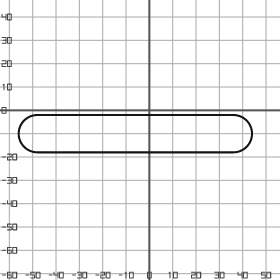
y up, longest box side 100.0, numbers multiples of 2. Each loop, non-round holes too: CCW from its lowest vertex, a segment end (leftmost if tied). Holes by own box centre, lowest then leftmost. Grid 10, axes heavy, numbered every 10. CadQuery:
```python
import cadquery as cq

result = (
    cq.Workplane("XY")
    .moveTo(-48.0, -18.0)
    .lineTo(36.0, -18.0)
    .threePointArc((44.0, -10.0), (36.0, -2.0))
    .lineTo(-48.0, -2.0)
    .threePointArc((-56.0, -10.0), (-48.0, -18.0))
    .close()
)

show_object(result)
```